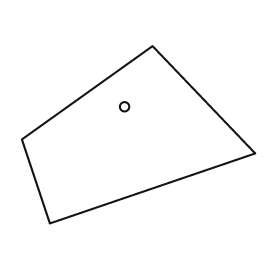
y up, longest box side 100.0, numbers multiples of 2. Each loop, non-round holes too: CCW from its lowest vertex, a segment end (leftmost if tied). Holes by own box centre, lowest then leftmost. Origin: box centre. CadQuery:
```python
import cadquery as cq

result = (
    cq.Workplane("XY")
    .moveTo(-38.0, -38.0)
    .lineTo(50.0, -8.0)
    .lineTo(6.0, 38.0)
    .lineTo(-50.0, -2.0)
    .close()
    .moveTo(-6.0, 12.0)
    .circle(2.0)
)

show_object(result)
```